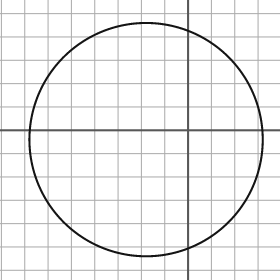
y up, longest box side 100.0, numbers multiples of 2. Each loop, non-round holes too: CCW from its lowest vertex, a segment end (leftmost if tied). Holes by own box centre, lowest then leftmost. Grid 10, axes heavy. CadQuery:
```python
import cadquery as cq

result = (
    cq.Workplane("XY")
    .moveTo(-18.0, -4.0)
    .circle(50.0)
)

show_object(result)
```